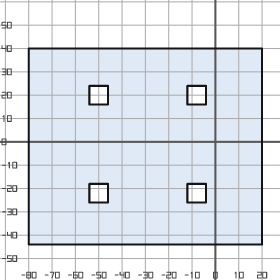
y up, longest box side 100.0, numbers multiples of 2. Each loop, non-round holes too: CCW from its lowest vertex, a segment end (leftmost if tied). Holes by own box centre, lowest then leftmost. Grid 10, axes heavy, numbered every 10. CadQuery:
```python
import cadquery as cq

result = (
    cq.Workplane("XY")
    .moveTo(-80.0, -44.0)
    .lineTo(20.0, -44.0)
    .lineTo(20.0, 40.0)
    .lineTo(-80.0, 40.0)
    .close()
    .moveTo(-54.0, -26.0)
    .lineTo(-46.0, -26.0)
    .lineTo(-46.0, -18.0)
    .lineTo(-54.0, -18.0)
    .close()
    .moveTo(-12.0, -26.0)
    .lineTo(-4.0, -26.0)
    .lineTo(-4.0, -18.0)
    .lineTo(-12.0, -18.0)
    .close()
    .moveTo(-54.0, 16.0)
    .lineTo(-46.0, 16.0)
    .lineTo(-46.0, 24.0)
    .lineTo(-54.0, 24.0)
    .close()
    .moveTo(-12.0, 16.0)
    .lineTo(-4.0, 16.0)
    .lineTo(-4.0, 24.0)
    .lineTo(-12.0, 24.0)
    .close()
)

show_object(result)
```